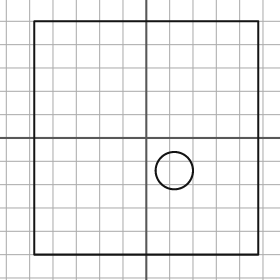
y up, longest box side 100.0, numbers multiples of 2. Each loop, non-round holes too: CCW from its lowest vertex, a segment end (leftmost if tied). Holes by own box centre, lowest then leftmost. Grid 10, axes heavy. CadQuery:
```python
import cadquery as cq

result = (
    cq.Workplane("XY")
    .moveTo(-48.0, -50.0)
    .lineTo(48.0, -50.0)
    .lineTo(48.0, 50.0)
    .lineTo(-48.0, 50.0)
    .close()
    .moveTo(12.0, -14.0)
    .circle(8.0)
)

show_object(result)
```